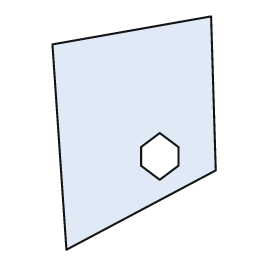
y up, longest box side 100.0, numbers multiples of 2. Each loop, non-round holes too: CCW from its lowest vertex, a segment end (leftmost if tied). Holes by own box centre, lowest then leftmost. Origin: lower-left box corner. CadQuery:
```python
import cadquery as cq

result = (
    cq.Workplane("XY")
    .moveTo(6.0, 0.0)
    .lineTo(70.0, 34.0)
    .lineTo(68.0, 100.0)
    .lineTo(0.0, 88.0)
    .close()
    .moveTo(46.0, 30.0)
    .lineTo(54.0, 36.0)
    .lineTo(54.0, 44.0)
    .lineTo(46.0, 50.0)
    .lineTo(38.0, 44.0)
    .lineTo(38.0, 36.0)
    .close()
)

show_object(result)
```